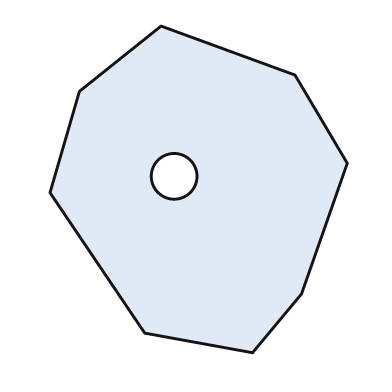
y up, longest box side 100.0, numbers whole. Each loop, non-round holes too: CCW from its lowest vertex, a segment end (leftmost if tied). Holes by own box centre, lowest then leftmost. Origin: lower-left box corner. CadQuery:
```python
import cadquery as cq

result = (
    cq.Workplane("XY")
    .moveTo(62.0, 0.0)
    .lineTo(77.0, 18.0)
    .lineTo(91.0, 58.0)
    .lineTo(75.0, 85.0)
    .lineTo(34.0, 100.0)
    .lineTo(9.0, 80.0)
    .lineTo(0.0, 49.0)
    .lineTo(29.0, 6.0)
    .close()
    .moveTo(38.0, 54.0)
    .circle(7.0)
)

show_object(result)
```